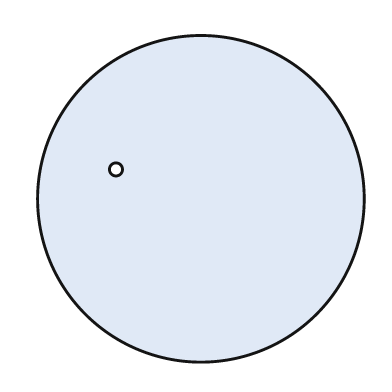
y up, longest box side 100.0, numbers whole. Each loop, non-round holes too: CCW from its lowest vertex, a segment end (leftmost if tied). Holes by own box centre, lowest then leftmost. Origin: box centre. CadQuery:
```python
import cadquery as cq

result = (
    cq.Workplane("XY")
    .moveTo(0.0, 0.0)
    .circle(50.0)
    .moveTo(-26.0, 9.0)
    .circle(2.0)
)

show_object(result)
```